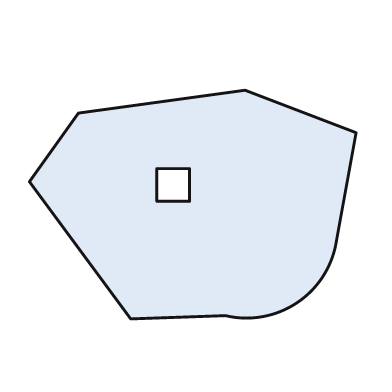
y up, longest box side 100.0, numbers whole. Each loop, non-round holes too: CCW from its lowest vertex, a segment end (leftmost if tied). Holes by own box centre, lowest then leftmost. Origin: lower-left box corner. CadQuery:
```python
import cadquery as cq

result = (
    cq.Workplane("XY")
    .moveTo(31.0, 0.0)
    .lineTo(60.0, 1.0)
    .threePointArc((82.0, 5.0), (94.0, 24.0))
    .lineTo(100.0, 57.0)
    .lineTo(66.0, 70.0)
    .lineTo(15.0, 63.0)
    .lineTo(0.0, 42.0)
    .close()
    .moveTo(39.0, 36.0)
    .lineTo(49.0, 36.0)
    .lineTo(49.0, 46.0)
    .lineTo(39.0, 46.0)
    .close()
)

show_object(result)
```